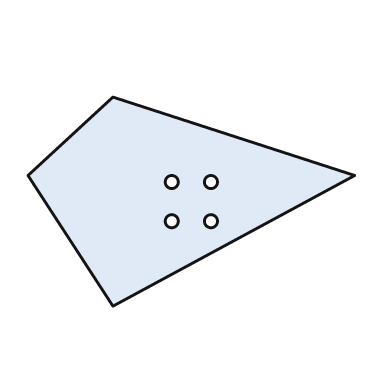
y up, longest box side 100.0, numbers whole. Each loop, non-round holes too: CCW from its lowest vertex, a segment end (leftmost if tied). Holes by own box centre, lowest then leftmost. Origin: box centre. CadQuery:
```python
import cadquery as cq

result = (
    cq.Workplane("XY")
    .moveTo(-24.0, -32.0)
    .lineTo(50.0, 8.0)
    .lineTo(-24.0, 32.0)
    .lineTo(-50.0, 8.0)
    .close()
    .moveTo(-6.0, -6.0)
    .circle(2.0)
    .moveTo(6.0, -6.0)
    .circle(2.0)
    .moveTo(-6.0, 6.0)
    .circle(2.0)
    .moveTo(6.0, 6.0)
    .circle(2.0)
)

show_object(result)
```